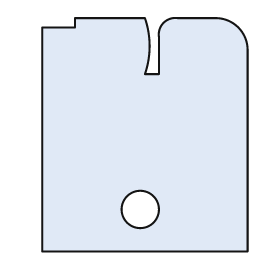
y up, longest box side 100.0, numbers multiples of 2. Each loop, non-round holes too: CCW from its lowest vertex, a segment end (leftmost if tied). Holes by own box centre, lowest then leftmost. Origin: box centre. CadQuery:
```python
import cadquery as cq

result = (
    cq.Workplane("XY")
    .moveTo(-44.0, -50.0)
    .lineTo(44.0, -50.0)
    .lineTo(44.0, 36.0)
    .threePointArc((40.0, 46.0), (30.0, 50.0))
    .lineTo(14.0, 50.0)
    .threePointArc((8.0, 48.0), (6.0, 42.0))
    .lineTo(6.0, 26.0)
    .lineTo(0.0, 26.0)
    .threePointArc((2.0, 38.0), (0.0, 50.0))
    .lineTo(-30.0, 50.0)
    .lineTo(-30.0, 46.0)
    .lineTo(-44.0, 46.0)
    .close()
    .moveTo(-2.0, -32.0)
    .circle(8.0)
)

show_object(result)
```